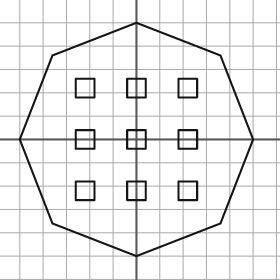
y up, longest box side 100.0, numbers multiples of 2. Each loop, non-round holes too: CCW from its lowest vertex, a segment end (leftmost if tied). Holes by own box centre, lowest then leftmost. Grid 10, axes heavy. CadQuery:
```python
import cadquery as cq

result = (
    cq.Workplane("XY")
    .moveTo(0.0, -50.0)
    .lineTo(36.0, -36.0)
    .lineTo(50.0, 0.0)
    .lineTo(36.0, 36.0)
    .lineTo(0.0, 50.0)
    .lineTo(-36.0, 36.0)
    .lineTo(-50.0, 0.0)
    .lineTo(-36.0, -36.0)
    .close()
    .moveTo(-26.0, -26.0)
    .lineTo(-18.0, -26.0)
    .lineTo(-18.0, -18.0)
    .lineTo(-26.0, -18.0)
    .close()
    .moveTo(-4.0, -26.0)
    .lineTo(4.0, -26.0)
    .lineTo(4.0, -18.0)
    .lineTo(-4.0, -18.0)
    .close()
    .moveTo(18.0, -26.0)
    .lineTo(26.0, -26.0)
    .lineTo(26.0, -18.0)
    .lineTo(18.0, -18.0)
    .close()
    .moveTo(-26.0, -4.0)
    .lineTo(-18.0, -4.0)
    .lineTo(-18.0, 4.0)
    .lineTo(-26.0, 4.0)
    .close()
    .moveTo(-4.0, -4.0)
    .lineTo(4.0, -4.0)
    .lineTo(4.0, 4.0)
    .lineTo(-4.0, 4.0)
    .close()
    .moveTo(18.0, -4.0)
    .lineTo(26.0, -4.0)
    .lineTo(26.0, 4.0)
    .lineTo(18.0, 4.0)
    .close()
    .moveTo(-26.0, 18.0)
    .lineTo(-18.0, 18.0)
    .lineTo(-18.0, 26.0)
    .lineTo(-26.0, 26.0)
    .close()
    .moveTo(-4.0, 18.0)
    .lineTo(4.0, 18.0)
    .lineTo(4.0, 26.0)
    .lineTo(-4.0, 26.0)
    .close()
    .moveTo(18.0, 18.0)
    .lineTo(26.0, 18.0)
    .lineTo(26.0, 26.0)
    .lineTo(18.0, 26.0)
    .close()
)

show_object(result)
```